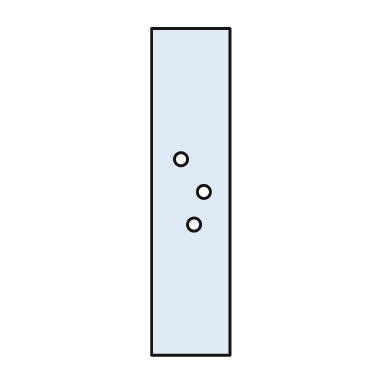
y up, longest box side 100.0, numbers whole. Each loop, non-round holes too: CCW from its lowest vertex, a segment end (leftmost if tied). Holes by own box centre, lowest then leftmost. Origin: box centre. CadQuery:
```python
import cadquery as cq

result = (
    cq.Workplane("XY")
    .moveTo(-12.0, -50.0)
    .lineTo(12.0, -50.0)
    .lineTo(12.0, 50.0)
    .lineTo(-12.0, 50.0)
    .close()
    .moveTo(1.0, -10.0)
    .circle(2.0)
    .moveTo(4.0, 0.0)
    .circle(2.0)
    .moveTo(-3.0, 10.0)
    .circle(2.0)
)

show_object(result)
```